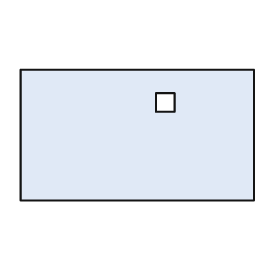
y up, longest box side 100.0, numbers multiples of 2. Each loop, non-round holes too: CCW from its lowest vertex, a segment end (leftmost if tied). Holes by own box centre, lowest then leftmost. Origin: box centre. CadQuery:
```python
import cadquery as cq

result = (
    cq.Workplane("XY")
    .moveTo(-50.0, -28.0)
    .lineTo(50.0, -28.0)
    .lineTo(50.0, 28.0)
    .lineTo(-50.0, 28.0)
    .close()
    .moveTo(8.0, 10.0)
    .lineTo(16.0, 10.0)
    .lineTo(16.0, 18.0)
    .lineTo(8.0, 18.0)
    .close()
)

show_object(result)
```